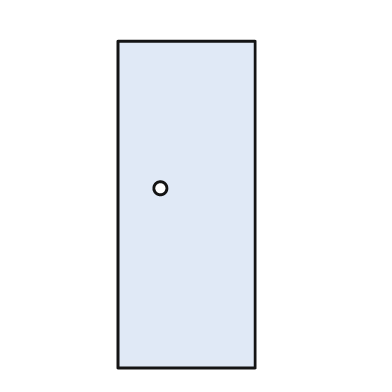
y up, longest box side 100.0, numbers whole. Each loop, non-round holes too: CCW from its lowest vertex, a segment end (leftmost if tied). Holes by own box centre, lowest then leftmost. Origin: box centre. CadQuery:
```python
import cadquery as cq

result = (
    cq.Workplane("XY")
    .moveTo(-21.0, -50.0)
    .lineTo(21.0, -50.0)
    .lineTo(21.0, 50.0)
    .lineTo(-21.0, 50.0)
    .close()
    .moveTo(-8.0, 5.0)
    .circle(2.0)
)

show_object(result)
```